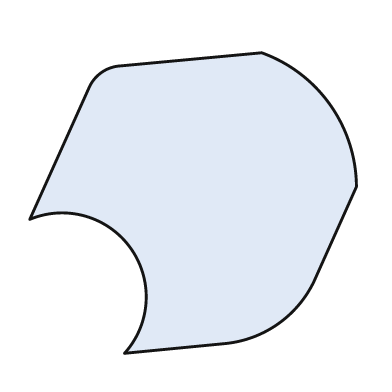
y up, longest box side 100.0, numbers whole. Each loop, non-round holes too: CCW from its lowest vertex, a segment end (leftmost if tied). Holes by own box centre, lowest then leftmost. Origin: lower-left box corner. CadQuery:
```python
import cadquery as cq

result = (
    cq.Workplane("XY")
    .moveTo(29.0, 0.0)
    .lineTo(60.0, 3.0)
    .threePointArc((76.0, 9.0), (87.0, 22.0))
    .lineTo(100.0, 51.0)
    .threePointArc((92.0, 76.0), (71.0, 92.0))
    .lineTo(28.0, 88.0)
    .threePointArc((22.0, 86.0), (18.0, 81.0))
    .lineTo(0.0, 41.0)
    .threePointArc((31.0, 32.0), (29.0, 0.0))
    .close()
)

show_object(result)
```